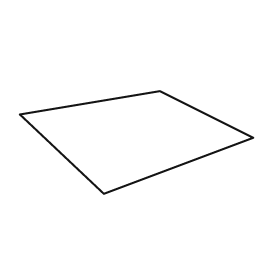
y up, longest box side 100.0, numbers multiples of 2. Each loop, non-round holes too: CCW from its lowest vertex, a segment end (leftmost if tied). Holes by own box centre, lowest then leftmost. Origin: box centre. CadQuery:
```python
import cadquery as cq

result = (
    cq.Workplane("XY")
    .moveTo(-14.0, -22.0)
    .lineTo(50.0, 2.0)
    .lineTo(10.0, 22.0)
    .lineTo(-50.0, 12.0)
    .close()
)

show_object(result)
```